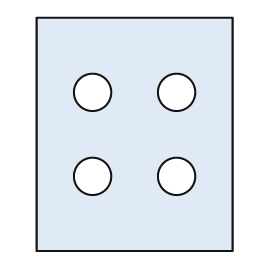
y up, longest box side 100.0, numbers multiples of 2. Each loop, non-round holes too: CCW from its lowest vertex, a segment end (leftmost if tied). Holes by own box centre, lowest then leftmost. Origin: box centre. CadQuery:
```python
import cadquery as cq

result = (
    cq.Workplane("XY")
    .moveTo(-42.0, -50.0)
    .lineTo(42.0, -50.0)
    .lineTo(42.0, 50.0)
    .lineTo(-42.0, 50.0)
    .close()
    .moveTo(-18.0, -18.0)
    .circle(8.0)
    .moveTo(18.0, -18.0)
    .circle(8.0)
    .moveTo(-18.0, 18.0)
    .circle(8.0)
    .moveTo(18.0, 18.0)
    .circle(8.0)
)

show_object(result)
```